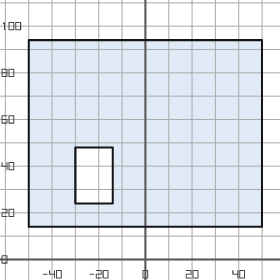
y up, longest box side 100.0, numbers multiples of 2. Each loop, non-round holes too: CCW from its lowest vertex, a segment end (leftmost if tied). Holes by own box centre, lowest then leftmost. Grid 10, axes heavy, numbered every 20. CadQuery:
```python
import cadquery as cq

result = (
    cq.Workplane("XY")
    .moveTo(-50.0, 14.0)
    .lineTo(50.0, 14.0)
    .lineTo(50.0, 94.0)
    .lineTo(-50.0, 94.0)
    .close()
    .moveTo(-30.0, 24.0)
    .lineTo(-14.0, 24.0)
    .lineTo(-14.0, 48.0)
    .lineTo(-30.0, 48.0)
    .close()
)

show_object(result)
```